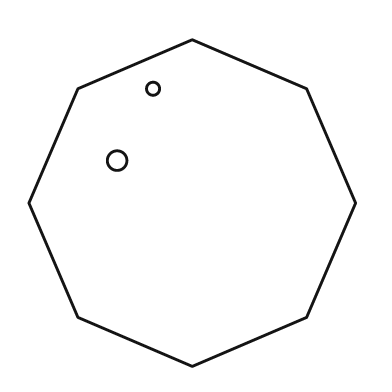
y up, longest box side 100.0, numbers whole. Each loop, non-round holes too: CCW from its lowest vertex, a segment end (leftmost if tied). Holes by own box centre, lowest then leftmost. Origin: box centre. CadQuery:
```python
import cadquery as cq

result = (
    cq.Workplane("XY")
    .moveTo(0.0, -50.0)
    .lineTo(35.0, -35.0)
    .lineTo(50.0, 0.0)
    .lineTo(35.0, 35.0)
    .lineTo(0.0, 50.0)
    .lineTo(-35.0, 35.0)
    .lineTo(-50.0, 0.0)
    .lineTo(-35.0, -35.0)
    .close()
    .moveTo(-23.0, 13.0)
    .circle(3.0)
    .moveTo(-12.0, 35.0)
    .circle(2.0)
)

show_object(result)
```